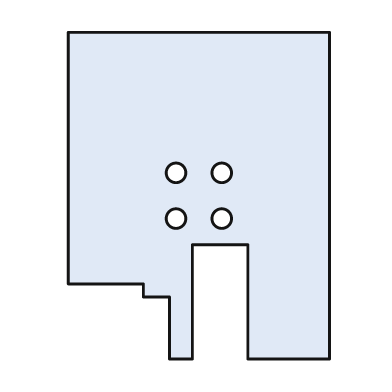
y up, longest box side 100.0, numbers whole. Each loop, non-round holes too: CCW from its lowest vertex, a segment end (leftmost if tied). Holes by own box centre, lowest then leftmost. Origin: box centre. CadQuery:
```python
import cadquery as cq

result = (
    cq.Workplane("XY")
    .moveTo(-9.0, -50.0)
    .lineTo(-2.0, -50.0)
    .lineTo(-2.0, -15.0)
    .lineTo(15.0, -15.0)
    .lineTo(15.0, -50.0)
    .lineTo(40.0, -50.0)
    .lineTo(40.0, 50.0)
    .lineTo(-40.0, 50.0)
    .lineTo(-40.0, -27.0)
    .lineTo(-17.0, -27.0)
    .lineTo(-17.0, -31.0)
    .lineTo(-9.0, -31.0)
    .close()
    .moveTo(-7.0, -7.0)
    .circle(3.0)
    .moveTo(7.0, -7.0)
    .circle(3.0)
    .moveTo(-7.0, 7.0)
    .circle(3.0)
    .moveTo(7.0, 7.0)
    .circle(3.0)
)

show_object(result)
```